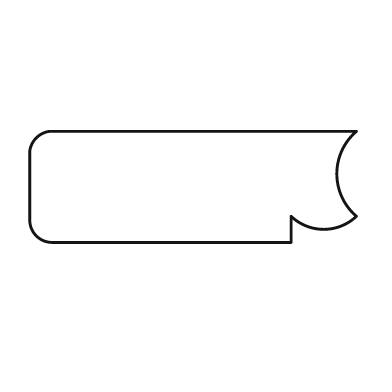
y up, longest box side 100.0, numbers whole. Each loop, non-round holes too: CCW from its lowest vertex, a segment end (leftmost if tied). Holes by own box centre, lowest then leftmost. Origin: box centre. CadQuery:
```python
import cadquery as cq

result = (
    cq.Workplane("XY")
    .moveTo(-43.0, -17.0)
    .lineTo(30.0, -17.0)
    .lineTo(30.0, -9.0)
    .threePointArc((40.0, -13.0), (50.0, -9.0))
    .threePointArc((44.0, 4.0), (50.0, 17.0))
    .lineTo(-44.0, 17.0)
    .threePointArc((-48.0, 15.0), (-50.0, 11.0))
    .lineTo(-50.0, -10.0)
    .threePointArc((-48.0, -15.0), (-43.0, -17.0))
    .close()
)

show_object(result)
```